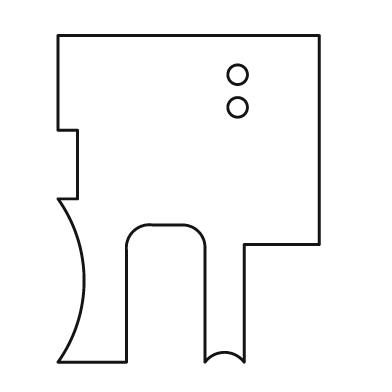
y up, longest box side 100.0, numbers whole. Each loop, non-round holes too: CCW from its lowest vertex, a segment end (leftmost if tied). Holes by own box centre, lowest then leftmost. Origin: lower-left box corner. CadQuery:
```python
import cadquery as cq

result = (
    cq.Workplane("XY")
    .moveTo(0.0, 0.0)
    .lineTo(21.0, 0.0)
    .lineTo(21.0, 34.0)
    .threePointArc((23.0, 40.0), (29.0, 42.0))
    .lineTo(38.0, 42.0)
    .threePointArc((43.0, 40.0), (45.0, 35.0))
    .lineTo(45.0, 0.0)
    .threePointArc((51.0, 3.0), (57.0, 0.0))
    .lineTo(57.0, 36.0)
    .lineTo(80.0, 36.0)
    .lineTo(80.0, 100.0)
    .lineTo(0.0, 100.0)
    .lineTo(0.0, 71.0)
    .lineTo(6.0, 71.0)
    .lineTo(6.0, 50.0)
    .lineTo(0.0, 50.0)
    .threePointArc((8.0, 25.0), (0.0, 0.0))
    .close()
    .moveTo(55.0, 78.0)
    .circle(3.0)
    .moveTo(55.0, 88.0)
    .circle(3.0)
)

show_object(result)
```